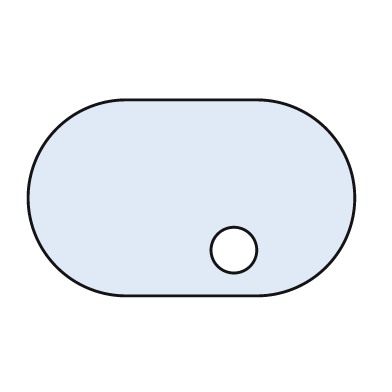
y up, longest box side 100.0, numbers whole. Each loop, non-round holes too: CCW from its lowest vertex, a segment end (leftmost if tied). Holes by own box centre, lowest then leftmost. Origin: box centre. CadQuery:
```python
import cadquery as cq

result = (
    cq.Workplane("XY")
    .moveTo(-20.0, -30.0)
    .lineTo(20.0, -30.0)
    .threePointArc((50.0, 0.0), (20.0, 30.0))
    .lineTo(-20.0, 30.0)
    .threePointArc((-50.0, 0.0), (-20.0, -30.0))
    .close()
    .moveTo(13.0, -16.0)
    .circle(7.0)
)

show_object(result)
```